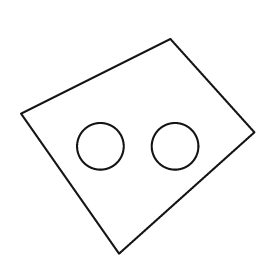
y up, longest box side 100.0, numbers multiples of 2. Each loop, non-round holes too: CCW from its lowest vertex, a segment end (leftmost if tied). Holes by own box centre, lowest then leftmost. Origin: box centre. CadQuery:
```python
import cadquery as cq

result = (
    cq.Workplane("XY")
    .moveTo(-8.0, -46.0)
    .lineTo(50.0, 6.0)
    .lineTo(14.0, 46.0)
    .lineTo(-50.0, 14.0)
    .close()
    .moveTo(-16.0, 0.0)
    .circle(10.0)
    .moveTo(16.0, 0.0)
    .circle(10.0)
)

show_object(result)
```